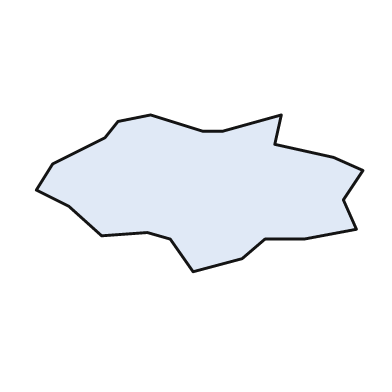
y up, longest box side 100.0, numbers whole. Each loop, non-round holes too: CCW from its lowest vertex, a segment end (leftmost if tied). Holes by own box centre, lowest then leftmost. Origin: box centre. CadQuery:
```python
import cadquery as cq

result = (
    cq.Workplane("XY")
    .moveTo(-2.0, -24.0)
    .lineTo(13.0, -20.0)
    .lineTo(20.0, -14.0)
    .lineTo(32.0, -14.0)
    .lineTo(48.0, -11.0)
    .lineTo(44.0, -2.0)
    .lineTo(50.0, 7.0)
    .lineTo(41.0, 11.0)
    .lineTo(23.0, 15.0)
    .lineTo(25.0, 24.0)
    .lineTo(7.0, 19.0)
    .lineTo(1.0, 19.0)
    .lineTo(-15.0, 24.0)
    .lineTo(-25.0, 22.0)
    .lineTo(-29.0, 17.0)
    .lineTo(-45.0, 9.0)
    .lineTo(-50.0, 1.0)
    .lineTo(-40.0, -4.0)
    .lineTo(-30.0, -13.0)
    .lineTo(-16.0, -12.0)
    .lineTo(-9.0, -14.0)
    .close()
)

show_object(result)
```